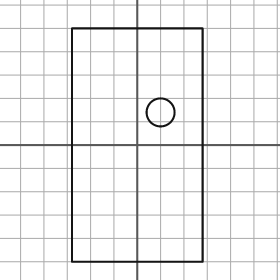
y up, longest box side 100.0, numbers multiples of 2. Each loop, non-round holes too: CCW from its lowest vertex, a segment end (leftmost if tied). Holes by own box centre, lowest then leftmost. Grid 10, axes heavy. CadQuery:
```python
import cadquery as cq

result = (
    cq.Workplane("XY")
    .moveTo(-28.0, -50.0)
    .lineTo(28.0, -50.0)
    .lineTo(28.0, 50.0)
    .lineTo(-28.0, 50.0)
    .close()
    .moveTo(10.0, 14.0)
    .circle(6.0)
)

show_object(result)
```